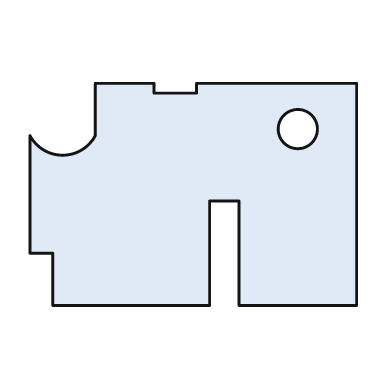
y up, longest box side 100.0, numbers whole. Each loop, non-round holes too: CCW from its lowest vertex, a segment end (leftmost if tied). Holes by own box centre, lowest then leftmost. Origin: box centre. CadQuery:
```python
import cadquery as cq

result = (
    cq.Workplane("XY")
    .moveTo(-43.0, -34.0)
    .lineTo(5.0, -34.0)
    .lineTo(5.0, -2.0)
    .lineTo(14.0, -2.0)
    .lineTo(14.0, -34.0)
    .lineTo(50.0, -34.0)
    .lineTo(50.0, 34.0)
    .lineTo(1.0, 34.0)
    .lineTo(1.0, 31.0)
    .lineTo(-12.0, 31.0)
    .lineTo(-12.0, 34.0)
    .lineTo(-30.0, 34.0)
    .lineTo(-30.0, 18.0)
    .threePointArc((-40.0, 12.0), (-50.0, 18.0))
    .lineTo(-50.0, -18.0)
    .lineTo(-43.0, -18.0)
    .close()
    .moveTo(32.0, 20.0)
    .circle(6.0)
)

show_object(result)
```